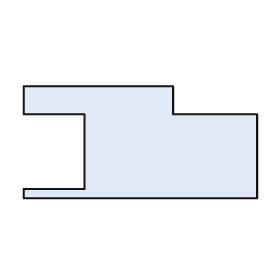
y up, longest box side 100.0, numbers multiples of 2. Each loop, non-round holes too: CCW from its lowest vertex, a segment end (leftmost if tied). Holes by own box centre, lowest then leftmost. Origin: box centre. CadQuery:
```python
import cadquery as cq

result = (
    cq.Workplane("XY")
    .moveTo(-50.0, -24.0)
    .lineTo(50.0, -24.0)
    .lineTo(50.0, 12.0)
    .lineTo(14.0, 12.0)
    .lineTo(14.0, 24.0)
    .lineTo(-50.0, 24.0)
    .lineTo(-50.0, 12.0)
    .lineTo(-24.0, 12.0)
    .lineTo(-24.0, -20.0)
    .lineTo(-50.0, -20.0)
    .close()
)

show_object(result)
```